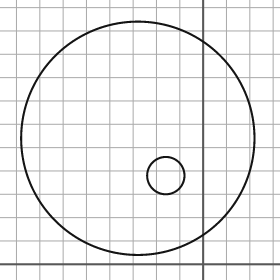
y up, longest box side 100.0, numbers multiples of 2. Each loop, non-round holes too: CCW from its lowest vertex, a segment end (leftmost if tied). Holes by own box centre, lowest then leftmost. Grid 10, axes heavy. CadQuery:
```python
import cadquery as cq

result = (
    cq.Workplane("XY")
    .moveTo(-28.0, 54.0)
    .circle(50.0)
    .moveTo(-16.0, 38.0)
    .circle(8.0)
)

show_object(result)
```